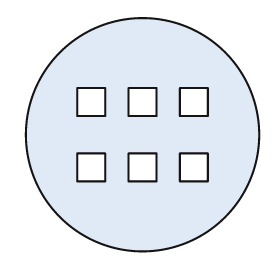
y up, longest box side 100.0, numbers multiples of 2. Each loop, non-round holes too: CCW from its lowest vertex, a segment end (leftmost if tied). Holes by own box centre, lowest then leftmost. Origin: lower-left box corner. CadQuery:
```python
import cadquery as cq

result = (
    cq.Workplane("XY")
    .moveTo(50.0, 50.0)
    .circle(50.0)
    .moveTo(22.0, 30.0)
    .lineTo(34.0, 30.0)
    .lineTo(34.0, 42.0)
    .lineTo(22.0, 42.0)
    .close()
    .moveTo(44.0, 30.0)
    .lineTo(56.0, 30.0)
    .lineTo(56.0, 42.0)
    .lineTo(44.0, 42.0)
    .close()
    .moveTo(66.0, 30.0)
    .lineTo(78.0, 30.0)
    .lineTo(78.0, 42.0)
    .lineTo(66.0, 42.0)
    .close()
    .moveTo(22.0, 58.0)
    .lineTo(34.0, 58.0)
    .lineTo(34.0, 70.0)
    .lineTo(22.0, 70.0)
    .close()
    .moveTo(44.0, 58.0)
    .lineTo(56.0, 58.0)
    .lineTo(56.0, 70.0)
    .lineTo(44.0, 70.0)
    .close()
    .moveTo(66.0, 58.0)
    .lineTo(78.0, 58.0)
    .lineTo(78.0, 70.0)
    .lineTo(66.0, 70.0)
    .close()
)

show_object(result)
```